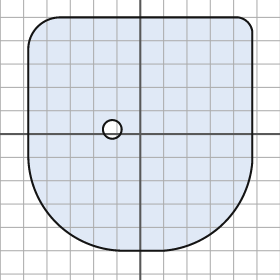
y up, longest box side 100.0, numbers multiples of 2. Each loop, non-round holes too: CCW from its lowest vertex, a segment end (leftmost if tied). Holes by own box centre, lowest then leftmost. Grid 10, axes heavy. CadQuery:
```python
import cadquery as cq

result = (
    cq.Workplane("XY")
    .moveTo(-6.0, -50.0)
    .lineTo(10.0, -50.0)
    .threePointArc((36.0, -38.0), (48.0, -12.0))
    .lineTo(48.0, 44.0)
    .threePointArc((46.0, 48.0), (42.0, 50.0))
    .lineTo(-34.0, 50.0)
    .threePointArc((-44.0, 46.0), (-48.0, 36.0))
    .lineTo(-48.0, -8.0)
    .threePointArc((-36.0, -38.0), (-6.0, -50.0))
    .close()
    .moveTo(-12.0, 2.0)
    .circle(4.0)
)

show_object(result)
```